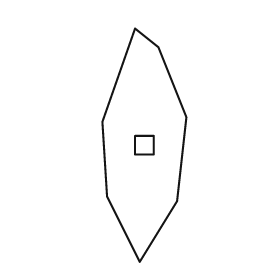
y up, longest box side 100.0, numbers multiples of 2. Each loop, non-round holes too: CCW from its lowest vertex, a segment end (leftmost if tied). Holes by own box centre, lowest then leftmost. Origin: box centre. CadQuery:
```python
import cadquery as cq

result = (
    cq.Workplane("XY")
    .moveTo(-2.0, -50.0)
    .lineTo(14.0, -24.0)
    .lineTo(18.0, 12.0)
    .lineTo(6.0, 42.0)
    .lineTo(-4.0, 50.0)
    .lineTo(-18.0, 10.0)
    .lineTo(-16.0, -22.0)
    .close()
    .moveTo(-4.0, -4.0)
    .lineTo(4.0, -4.0)
    .lineTo(4.0, 4.0)
    .lineTo(-4.0, 4.0)
    .close()
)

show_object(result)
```